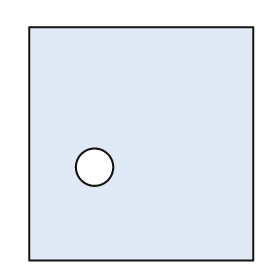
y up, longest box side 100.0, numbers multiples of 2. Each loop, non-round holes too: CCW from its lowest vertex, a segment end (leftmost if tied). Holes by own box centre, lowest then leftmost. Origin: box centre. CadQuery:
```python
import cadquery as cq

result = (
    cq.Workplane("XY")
    .moveTo(-48.0, -50.0)
    .lineTo(48.0, -50.0)
    .lineTo(48.0, 50.0)
    .lineTo(-48.0, 50.0)
    .close()
    .moveTo(-20.0, -10.0)
    .circle(8.0)
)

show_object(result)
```